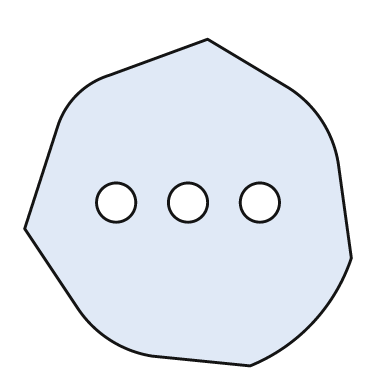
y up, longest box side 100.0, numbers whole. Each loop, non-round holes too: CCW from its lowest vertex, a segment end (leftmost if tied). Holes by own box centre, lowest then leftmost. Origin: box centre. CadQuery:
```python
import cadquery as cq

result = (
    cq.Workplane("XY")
    .moveTo(19.0, -50.0)
    .threePointArc((38.0, -37.0), (50.0, -17.0))
    .lineTo(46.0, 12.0)
    .threePointArc((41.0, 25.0), (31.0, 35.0))
    .lineTo(6.0, 50.0)
    .lineTo(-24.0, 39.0)
    .threePointArc((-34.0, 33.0), (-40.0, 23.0))
    .lineTo(-50.0, -8.0)
    .lineTo(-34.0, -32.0)
    .threePointArc((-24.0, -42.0), (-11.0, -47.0))
    .close()
    .moveTo(-22.0, 0.0)
    .circle(6.0)
    .moveTo(0.0, 0.0)
    .circle(6.0)
    .moveTo(22.0, 0.0)
    .circle(6.0)
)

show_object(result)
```